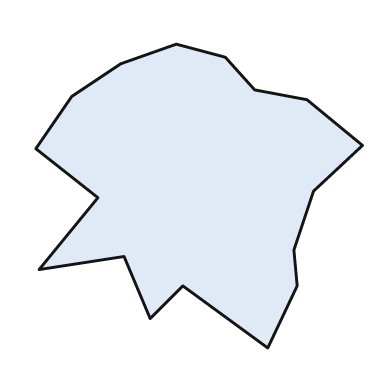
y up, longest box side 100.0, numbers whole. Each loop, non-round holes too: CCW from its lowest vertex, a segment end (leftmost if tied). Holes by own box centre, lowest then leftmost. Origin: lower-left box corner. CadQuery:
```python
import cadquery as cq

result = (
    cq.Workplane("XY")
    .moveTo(71.0, 0.0)
    .lineTo(80.0, 19.0)
    .lineTo(79.0, 30.0)
    .lineTo(85.0, 48.0)
    .lineTo(100.0, 62.0)
    .lineTo(83.0, 76.0)
    .lineTo(67.0, 79.0)
    .lineTo(58.0, 89.0)
    .lineTo(43.0, 93.0)
    .lineTo(26.0, 87.0)
    .lineTo(11.0, 77.0)
    .lineTo(0.0, 61.0)
    .lineTo(19.0, 46.0)
    .lineTo(1.0, 24.0)
    .lineTo(27.0, 28.0)
    .lineTo(35.0, 9.0)
    .lineTo(45.0, 19.0)
    .close()
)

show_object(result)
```